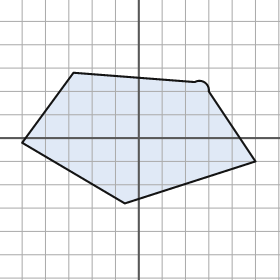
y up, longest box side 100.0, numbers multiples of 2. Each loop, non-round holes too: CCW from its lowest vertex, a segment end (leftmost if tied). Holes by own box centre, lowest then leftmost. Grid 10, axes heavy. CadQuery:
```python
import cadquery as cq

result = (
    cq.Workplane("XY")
    .moveTo(-6.0, -28.0)
    .lineTo(50.0, -10.0)
    .lineTo(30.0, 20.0)
    .threePointArc((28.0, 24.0), (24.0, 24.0))
    .lineTo(-28.0, 28.0)
    .lineTo(-50.0, -2.0)
    .close()
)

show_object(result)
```